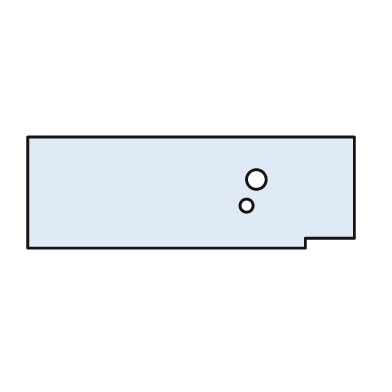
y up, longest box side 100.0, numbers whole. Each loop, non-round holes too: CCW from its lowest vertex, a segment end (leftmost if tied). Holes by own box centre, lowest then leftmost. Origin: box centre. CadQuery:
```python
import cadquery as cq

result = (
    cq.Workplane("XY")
    .moveTo(-50.0, -17.0)
    .lineTo(35.0, -17.0)
    .lineTo(35.0, -14.0)
    .lineTo(50.0, -14.0)
    .lineTo(50.0, 17.0)
    .lineTo(-50.0, 17.0)
    .close()
    .moveTo(17.0, -4.0)
    .circle(2.0)
    .moveTo(20.0, 4.0)
    .circle(3.0)
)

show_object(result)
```